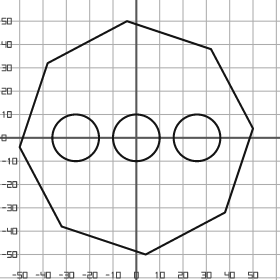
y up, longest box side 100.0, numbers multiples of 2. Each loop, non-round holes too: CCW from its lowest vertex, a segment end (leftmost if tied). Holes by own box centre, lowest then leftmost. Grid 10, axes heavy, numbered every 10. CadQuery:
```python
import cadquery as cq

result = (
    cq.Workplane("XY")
    .moveTo(4.0, -50.0)
    .lineTo(38.0, -32.0)
    .lineTo(50.0, 4.0)
    .lineTo(32.0, 38.0)
    .lineTo(-4.0, 50.0)
    .lineTo(-38.0, 32.0)
    .lineTo(-50.0, -4.0)
    .lineTo(-32.0, -38.0)
    .close()
    .moveTo(-26.0, 0.0)
    .circle(10.0)
    .moveTo(0.0, 0.0)
    .circle(10.0)
    .moveTo(26.0, 0.0)
    .circle(10.0)
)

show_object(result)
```